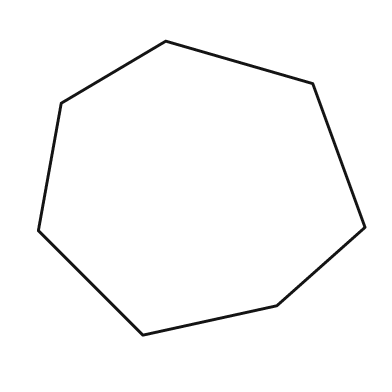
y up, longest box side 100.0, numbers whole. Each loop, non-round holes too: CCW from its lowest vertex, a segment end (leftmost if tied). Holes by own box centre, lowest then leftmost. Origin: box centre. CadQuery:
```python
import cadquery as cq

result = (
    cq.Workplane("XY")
    .moveTo(-18.0, -45.0)
    .lineTo(23.0, -36.0)
    .lineTo(50.0, -12.0)
    .lineTo(34.0, 32.0)
    .lineTo(-11.0, 45.0)
    .lineTo(-43.0, 26.0)
    .lineTo(-50.0, -13.0)
    .close()
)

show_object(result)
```